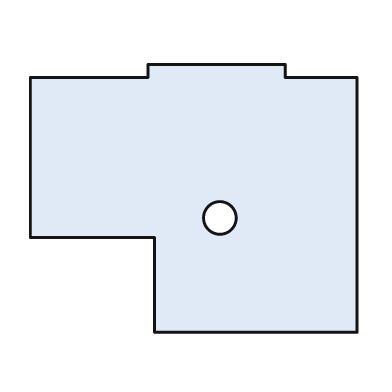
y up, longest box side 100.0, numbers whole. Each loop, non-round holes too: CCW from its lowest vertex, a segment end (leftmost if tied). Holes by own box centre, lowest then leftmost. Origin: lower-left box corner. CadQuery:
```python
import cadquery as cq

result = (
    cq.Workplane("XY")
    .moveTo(38.0, 0.0)
    .lineTo(100.0, 0.0)
    .lineTo(100.0, 78.0)
    .lineTo(78.0, 78.0)
    .lineTo(78.0, 82.0)
    .lineTo(36.0, 82.0)
    .lineTo(36.0, 78.0)
    .lineTo(0.0, 78.0)
    .lineTo(0.0, 29.0)
    .lineTo(38.0, 29.0)
    .close()
    .moveTo(58.0, 35.0)
    .circle(5.0)
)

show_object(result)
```